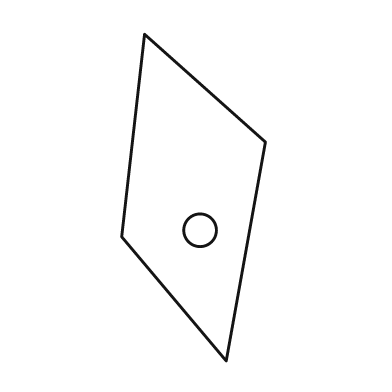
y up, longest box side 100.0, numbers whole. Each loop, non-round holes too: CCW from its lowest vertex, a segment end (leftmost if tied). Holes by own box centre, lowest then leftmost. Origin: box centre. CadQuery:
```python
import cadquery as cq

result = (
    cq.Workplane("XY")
    .moveTo(10.0, -50.0)
    .lineTo(22.0, 17.0)
    .lineTo(-15.0, 50.0)
    .lineTo(-22.0, -12.0)
    .close()
    .moveTo(2.0, -10.0)
    .circle(5.0)
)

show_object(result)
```